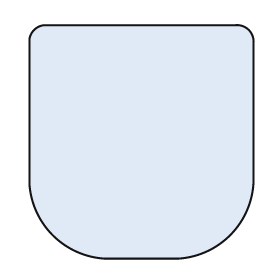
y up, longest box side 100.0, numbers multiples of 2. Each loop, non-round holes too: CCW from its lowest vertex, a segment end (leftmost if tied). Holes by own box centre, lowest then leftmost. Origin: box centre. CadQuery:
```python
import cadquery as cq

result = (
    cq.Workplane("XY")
    .moveTo(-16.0, -50.0)
    .lineTo(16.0, -50.0)
    .threePointArc((38.0, -40.0), (48.0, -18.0))
    .lineTo(48.0, 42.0)
    .threePointArc((46.0, 48.0), (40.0, 50.0))
    .lineTo(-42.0, 50.0)
    .threePointArc((-46.0, 48.0), (-48.0, 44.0))
    .lineTo(-48.0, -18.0)
    .threePointArc((-38.0, -40.0), (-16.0, -50.0))
    .close()
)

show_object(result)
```